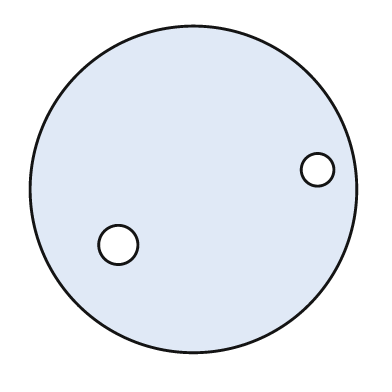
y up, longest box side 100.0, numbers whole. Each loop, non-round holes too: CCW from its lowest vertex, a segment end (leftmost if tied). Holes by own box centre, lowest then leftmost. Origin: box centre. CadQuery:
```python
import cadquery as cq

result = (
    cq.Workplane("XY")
    .moveTo(0.0, 0.0)
    .circle(50.0)
    .moveTo(-23.0, -17.0)
    .circle(6.0)
    .moveTo(38.0, 6.0)
    .circle(5.0)
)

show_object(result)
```